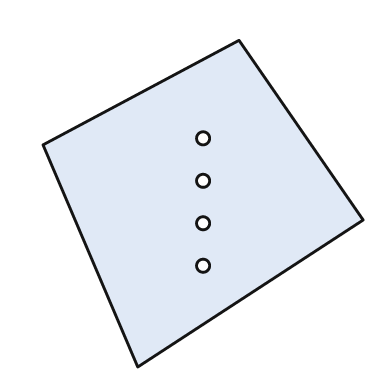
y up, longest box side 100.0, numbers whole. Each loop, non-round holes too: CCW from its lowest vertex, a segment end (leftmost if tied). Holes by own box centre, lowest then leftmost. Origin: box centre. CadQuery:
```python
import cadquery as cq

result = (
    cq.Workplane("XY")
    .moveTo(-20.0, -50.0)
    .lineTo(49.0, -5.0)
    .lineTo(11.0, 50.0)
    .lineTo(-49.0, 18.0)
    .close()
    .moveTo(0.0, -19.0)
    .circle(2.0)
    .moveTo(0.0, -6.0)
    .circle(2.0)
    .moveTo(0.0, 7.0)
    .circle(2.0)
    .moveTo(0.0, 20.0)
    .circle(2.0)
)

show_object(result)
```